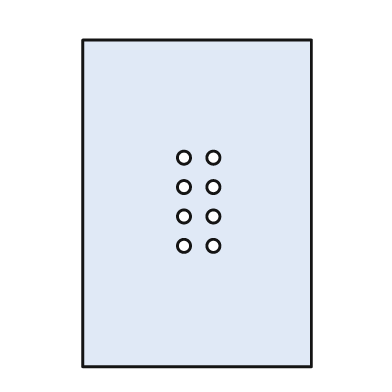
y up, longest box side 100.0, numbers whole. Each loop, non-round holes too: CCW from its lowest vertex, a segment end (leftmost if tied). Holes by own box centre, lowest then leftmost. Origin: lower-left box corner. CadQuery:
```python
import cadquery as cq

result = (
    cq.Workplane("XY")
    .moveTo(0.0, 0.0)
    .lineTo(70.0, 0.0)
    .lineTo(70.0, 100.0)
    .lineTo(0.0, 100.0)
    .close()
    .moveTo(31.0, 37.0)
    .circle(2.0)
    .moveTo(40.0, 37.0)
    .circle(2.0)
    .moveTo(31.0, 46.0)
    .circle(2.0)
    .moveTo(40.0, 46.0)
    .circle(2.0)
    .moveTo(31.0, 55.0)
    .circle(2.0)
    .moveTo(40.0, 55.0)
    .circle(2.0)
    .moveTo(31.0, 64.0)
    .circle(2.0)
    .moveTo(40.0, 64.0)
    .circle(2.0)
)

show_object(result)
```